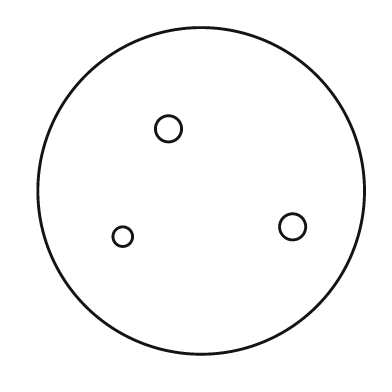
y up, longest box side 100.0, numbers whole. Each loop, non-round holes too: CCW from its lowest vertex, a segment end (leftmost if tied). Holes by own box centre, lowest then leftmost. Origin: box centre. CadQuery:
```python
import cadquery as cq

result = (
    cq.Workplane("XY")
    .moveTo(0.0, 0.0)
    .circle(50.0)
    .moveTo(-24.0, -14.0)
    .circle(3.0)
    .moveTo(28.0, -11.0)
    .circle(4.0)
    .moveTo(-10.0, 19.0)
    .circle(4.0)
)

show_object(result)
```